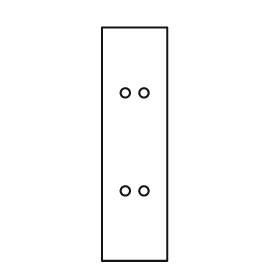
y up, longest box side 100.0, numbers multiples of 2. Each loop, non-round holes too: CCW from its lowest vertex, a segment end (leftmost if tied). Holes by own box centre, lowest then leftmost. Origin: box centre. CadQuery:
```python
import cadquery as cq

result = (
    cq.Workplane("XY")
    .moveTo(-14.0, -50.0)
    .lineTo(14.0, -50.0)
    .lineTo(14.0, 50.0)
    .lineTo(-14.0, 50.0)
    .close()
    .moveTo(-4.0, -20.0)
    .circle(2.0)
    .moveTo(4.0, -20.0)
    .circle(2.0)
    .moveTo(-4.0, 22.0)
    .circle(2.0)
    .moveTo(4.0, 22.0)
    .circle(2.0)
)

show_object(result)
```